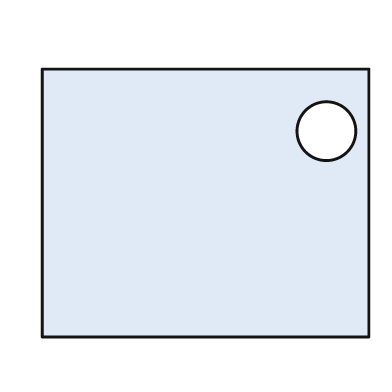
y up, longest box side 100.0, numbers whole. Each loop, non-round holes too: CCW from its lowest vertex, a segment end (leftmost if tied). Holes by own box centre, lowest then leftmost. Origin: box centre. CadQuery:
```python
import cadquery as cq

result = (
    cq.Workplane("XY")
    .moveTo(-50.0, -41.0)
    .lineTo(50.0, -41.0)
    .lineTo(50.0, 41.0)
    .lineTo(-50.0, 41.0)
    .close()
    .moveTo(37.0, 22.0)
    .circle(9.0)
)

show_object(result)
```